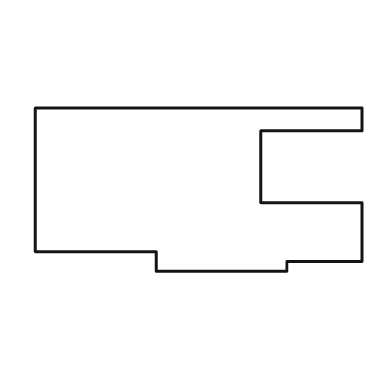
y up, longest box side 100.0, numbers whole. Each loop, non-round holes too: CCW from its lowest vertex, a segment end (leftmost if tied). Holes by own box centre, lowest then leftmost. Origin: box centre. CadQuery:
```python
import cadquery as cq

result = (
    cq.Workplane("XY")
    .moveTo(-13.0, -25.0)
    .lineTo(27.0, -25.0)
    .lineTo(27.0, -22.0)
    .lineTo(50.0, -22.0)
    .lineTo(50.0, -4.0)
    .lineTo(19.0, -4.0)
    .lineTo(19.0, 18.0)
    .lineTo(50.0, 18.0)
    .lineTo(50.0, 25.0)
    .lineTo(-50.0, 25.0)
    .lineTo(-50.0, -19.0)
    .lineTo(-13.0, -19.0)
    .close()
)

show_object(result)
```